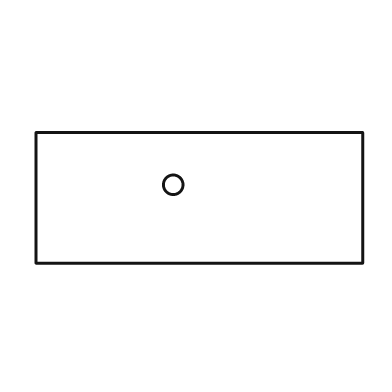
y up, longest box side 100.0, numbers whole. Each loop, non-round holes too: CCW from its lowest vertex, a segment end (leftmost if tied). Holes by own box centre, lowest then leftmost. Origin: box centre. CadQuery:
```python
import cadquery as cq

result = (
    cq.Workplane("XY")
    .moveTo(-50.0, -20.0)
    .lineTo(50.0, -20.0)
    .lineTo(50.0, 20.0)
    .lineTo(-50.0, 20.0)
    .close()
    .moveTo(-8.0, 4.0)
    .circle(3.0)
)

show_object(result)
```